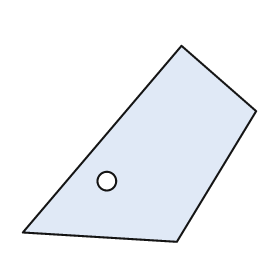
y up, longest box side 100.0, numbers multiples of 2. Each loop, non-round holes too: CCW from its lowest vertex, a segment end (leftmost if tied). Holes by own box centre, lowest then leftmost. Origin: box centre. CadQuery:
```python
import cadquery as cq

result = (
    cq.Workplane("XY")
    .moveTo(16.0, -42.0)
    .lineTo(50.0, 14.0)
    .lineTo(18.0, 42.0)
    .lineTo(-50.0, -38.0)
    .close()
    .moveTo(-14.0, -16.0)
    .circle(4.0)
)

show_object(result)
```